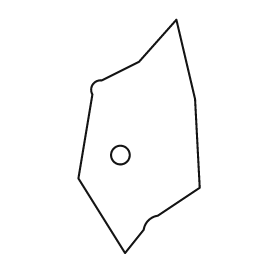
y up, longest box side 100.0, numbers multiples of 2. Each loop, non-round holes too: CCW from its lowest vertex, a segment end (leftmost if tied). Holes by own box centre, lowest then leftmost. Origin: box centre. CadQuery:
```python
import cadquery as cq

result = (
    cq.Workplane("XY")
    .moveTo(-6.0, -50.0)
    .lineTo(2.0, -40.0)
    .threePointArc((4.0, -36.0), (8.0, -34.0))
    .lineTo(26.0, -22.0)
    .lineTo(24.0, 16.0)
    .lineTo(16.0, 50.0)
    .lineTo(0.0, 32.0)
    .lineTo(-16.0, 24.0)
    .threePointArc((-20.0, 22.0), (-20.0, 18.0))
    .lineTo(-26.0, -18.0)
    .close()
    .moveTo(-8.0, -8.0)
    .circle(4.0)
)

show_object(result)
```